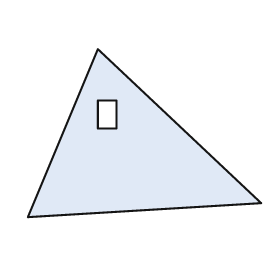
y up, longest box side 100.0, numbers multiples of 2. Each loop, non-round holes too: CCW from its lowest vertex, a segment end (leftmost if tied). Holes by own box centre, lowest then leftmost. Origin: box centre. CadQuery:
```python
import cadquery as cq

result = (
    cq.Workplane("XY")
    .moveTo(-50.0, -36.0)
    .lineTo(50.0, -30.0)
    .lineTo(-20.0, 36.0)
    .close()
    .moveTo(-20.0, 2.0)
    .lineTo(-12.0, 2.0)
    .lineTo(-12.0, 14.0)
    .lineTo(-20.0, 14.0)
    .close()
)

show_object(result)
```